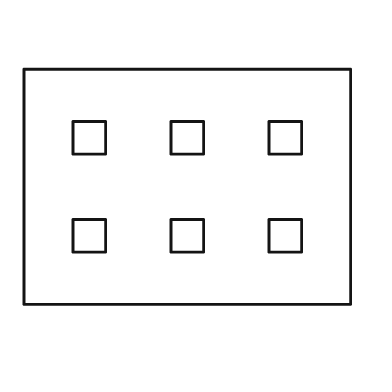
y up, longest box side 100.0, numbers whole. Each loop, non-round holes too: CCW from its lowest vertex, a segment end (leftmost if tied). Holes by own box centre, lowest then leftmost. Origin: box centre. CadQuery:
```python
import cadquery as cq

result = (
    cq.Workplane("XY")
    .moveTo(-50.0, -36.0)
    .lineTo(50.0, -36.0)
    .lineTo(50.0, 36.0)
    .lineTo(-50.0, 36.0)
    .close()
    .moveTo(-35.0, -20.0)
    .lineTo(-25.0, -20.0)
    .lineTo(-25.0, -10.0)
    .lineTo(-35.0, -10.0)
    .close()
    .moveTo(-5.0, -20.0)
    .lineTo(5.0, -20.0)
    .lineTo(5.0, -10.0)
    .lineTo(-5.0, -10.0)
    .close()
    .moveTo(25.0, -20.0)
    .lineTo(35.0, -20.0)
    .lineTo(35.0, -10.0)
    .lineTo(25.0, -10.0)
    .close()
    .moveTo(-35.0, 10.0)
    .lineTo(-25.0, 10.0)
    .lineTo(-25.0, 20.0)
    .lineTo(-35.0, 20.0)
    .close()
    .moveTo(-5.0, 10.0)
    .lineTo(5.0, 10.0)
    .lineTo(5.0, 20.0)
    .lineTo(-5.0, 20.0)
    .close()
    .moveTo(25.0, 10.0)
    .lineTo(35.0, 10.0)
    .lineTo(35.0, 20.0)
    .lineTo(25.0, 20.0)
    .close()
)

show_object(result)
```